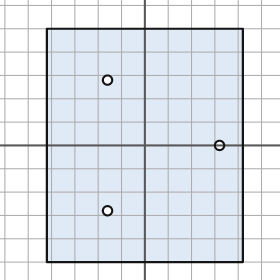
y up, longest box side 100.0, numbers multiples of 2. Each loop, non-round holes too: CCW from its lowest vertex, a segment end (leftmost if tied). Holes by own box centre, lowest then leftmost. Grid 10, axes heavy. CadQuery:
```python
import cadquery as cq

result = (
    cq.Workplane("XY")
    .moveTo(-42.0, -50.0)
    .lineTo(42.0, -50.0)
    .lineTo(42.0, 50.0)
    .lineTo(-42.0, 50.0)
    .close()
    .moveTo(-16.0, -28.0)
    .circle(2.0)
    .moveTo(32.0, 0.0)
    .circle(2.0)
    .moveTo(-16.0, 28.0)
    .circle(2.0)
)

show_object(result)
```